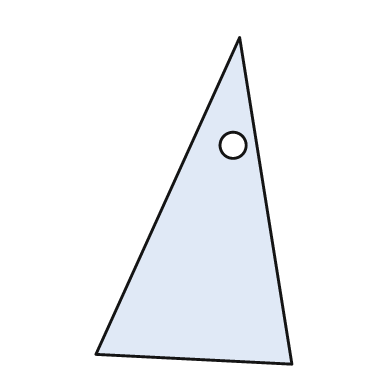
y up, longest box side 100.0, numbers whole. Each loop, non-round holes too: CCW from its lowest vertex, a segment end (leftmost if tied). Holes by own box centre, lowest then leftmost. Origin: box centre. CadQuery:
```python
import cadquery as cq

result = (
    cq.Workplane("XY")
    .moveTo(30.0, -50.0)
    .lineTo(14.0, 50.0)
    .lineTo(-30.0, -47.0)
    .close()
    .moveTo(12.0, 17.0)
    .circle(4.0)
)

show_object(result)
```